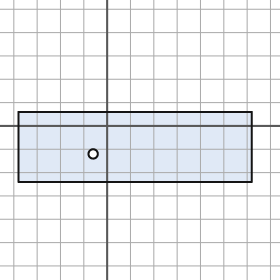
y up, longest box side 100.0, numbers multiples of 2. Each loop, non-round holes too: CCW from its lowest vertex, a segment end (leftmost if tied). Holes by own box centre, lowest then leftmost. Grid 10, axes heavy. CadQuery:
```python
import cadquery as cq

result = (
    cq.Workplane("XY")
    .moveTo(-38.0, -24.0)
    .lineTo(62.0, -24.0)
    .lineTo(62.0, 6.0)
    .lineTo(-38.0, 6.0)
    .close()
    .moveTo(-6.0, -12.0)
    .circle(2.0)
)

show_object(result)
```